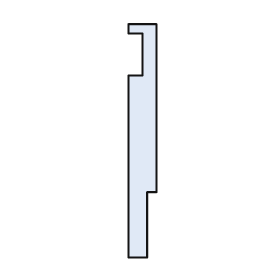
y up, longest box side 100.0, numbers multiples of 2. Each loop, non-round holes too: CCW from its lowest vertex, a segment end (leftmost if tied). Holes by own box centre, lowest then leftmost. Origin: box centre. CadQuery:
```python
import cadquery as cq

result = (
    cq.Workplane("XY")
    .moveTo(-6.0, -50.0)
    .lineTo(2.0, -50.0)
    .lineTo(2.0, -22.0)
    .lineTo(6.0, -22.0)
    .lineTo(6.0, 50.0)
    .lineTo(-6.0, 50.0)
    .lineTo(-6.0, 46.0)
    .lineTo(0.0, 46.0)
    .lineTo(0.0, 28.0)
    .lineTo(-6.0, 28.0)
    .close()
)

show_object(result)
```